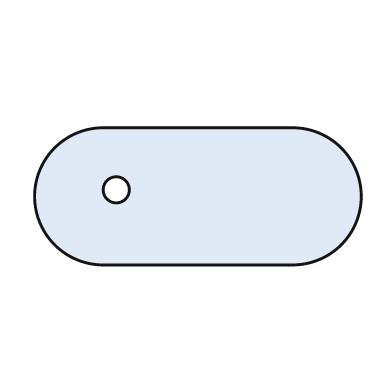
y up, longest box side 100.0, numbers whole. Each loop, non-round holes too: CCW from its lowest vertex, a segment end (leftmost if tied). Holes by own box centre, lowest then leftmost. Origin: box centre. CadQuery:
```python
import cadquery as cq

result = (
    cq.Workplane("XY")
    .moveTo(-29.0, -21.0)
    .lineTo(29.0, -21.0)
    .threePointArc((50.0, 0.0), (29.0, 21.0))
    .lineTo(-29.0, 21.0)
    .threePointArc((-50.0, 0.0), (-29.0, -21.0))
    .close()
    .moveTo(-25.0, 2.0)
    .circle(4.0)
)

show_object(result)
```